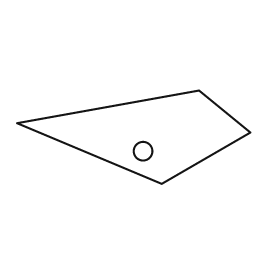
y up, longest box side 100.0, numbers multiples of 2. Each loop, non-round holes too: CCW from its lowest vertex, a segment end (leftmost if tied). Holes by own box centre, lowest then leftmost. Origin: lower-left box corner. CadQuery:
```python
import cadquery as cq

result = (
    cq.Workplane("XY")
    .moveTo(62.0, 0.0)
    .lineTo(100.0, 22.0)
    .lineTo(78.0, 40.0)
    .lineTo(0.0, 26.0)
    .close()
    .moveTo(54.0, 14.0)
    .circle(4.0)
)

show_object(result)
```